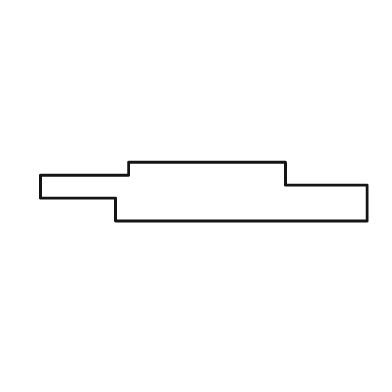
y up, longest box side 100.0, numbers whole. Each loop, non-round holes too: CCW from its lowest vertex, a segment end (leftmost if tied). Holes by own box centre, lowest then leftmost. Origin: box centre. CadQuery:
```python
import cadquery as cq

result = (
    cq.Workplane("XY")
    .moveTo(-27.0, -9.0)
    .lineTo(50.0, -9.0)
    .lineTo(50.0, 2.0)
    .lineTo(25.0, 2.0)
    .lineTo(25.0, 9.0)
    .lineTo(-23.0, 9.0)
    .lineTo(-23.0, 5.0)
    .lineTo(-50.0, 5.0)
    .lineTo(-50.0, -2.0)
    .lineTo(-27.0, -2.0)
    .close()
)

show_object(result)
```